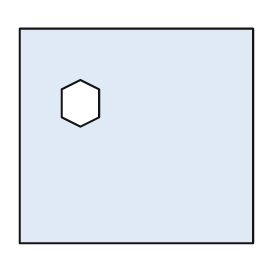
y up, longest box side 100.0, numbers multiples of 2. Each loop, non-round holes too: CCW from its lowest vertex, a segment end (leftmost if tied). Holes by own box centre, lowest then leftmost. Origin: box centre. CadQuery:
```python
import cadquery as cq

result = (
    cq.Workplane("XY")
    .moveTo(-50.0, -46.0)
    .lineTo(50.0, -46.0)
    .lineTo(50.0, 46.0)
    .lineTo(-50.0, 46.0)
    .close()
    .moveTo(-24.0, 4.0)
    .lineTo(-16.0, 8.0)
    .lineTo(-16.0, 20.0)
    .lineTo(-24.0, 24.0)
    .lineTo(-32.0, 20.0)
    .lineTo(-32.0, 8.0)
    .close()
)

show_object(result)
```